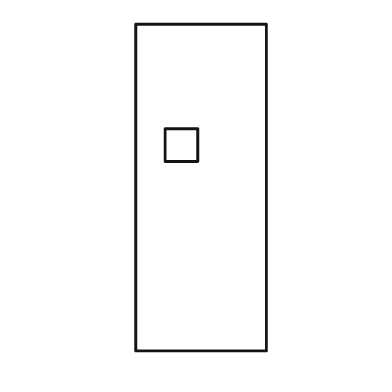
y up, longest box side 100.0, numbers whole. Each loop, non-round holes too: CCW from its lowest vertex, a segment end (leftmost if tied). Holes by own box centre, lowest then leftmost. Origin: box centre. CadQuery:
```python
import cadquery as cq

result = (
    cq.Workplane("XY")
    .moveTo(-20.0, -50.0)
    .lineTo(20.0, -50.0)
    .lineTo(20.0, 50.0)
    .lineTo(-20.0, 50.0)
    .close()
    .moveTo(-11.0, 8.0)
    .lineTo(-1.0, 8.0)
    .lineTo(-1.0, 18.0)
    .lineTo(-11.0, 18.0)
    .close()
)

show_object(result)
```